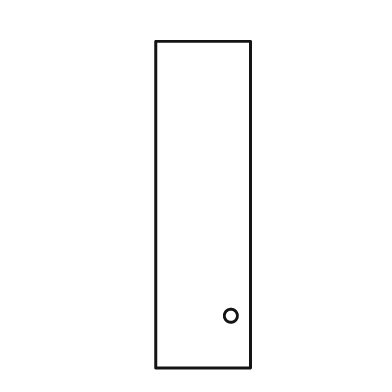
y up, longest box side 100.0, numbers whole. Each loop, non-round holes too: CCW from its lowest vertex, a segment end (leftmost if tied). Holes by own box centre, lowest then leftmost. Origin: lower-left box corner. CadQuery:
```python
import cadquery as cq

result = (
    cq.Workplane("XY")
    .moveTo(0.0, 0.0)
    .lineTo(29.0, 0.0)
    .lineTo(29.0, 100.0)
    .lineTo(0.0, 100.0)
    .close()
    .moveTo(23.0, 16.0)
    .circle(2.0)
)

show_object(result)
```